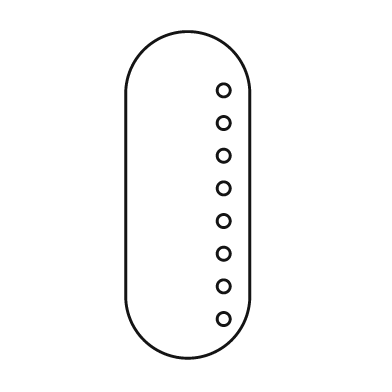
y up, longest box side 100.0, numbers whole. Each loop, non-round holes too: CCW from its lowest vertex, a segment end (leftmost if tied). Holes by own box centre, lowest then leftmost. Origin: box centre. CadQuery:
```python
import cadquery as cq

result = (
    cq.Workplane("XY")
    .moveTo(-19.0, -31.0)
    .threePointArc((0.0, -50.0), (19.0, -31.0))
    .lineTo(19.0, 31.0)
    .threePointArc((0.0, 50.0), (-19.0, 31.0))
    .close()
    .moveTo(11.0, -38.0)
    .circle(2.0)
    .moveTo(11.0, -28.0)
    .circle(2.0)
    .moveTo(11.0, -18.0)
    .circle(2.0)
    .moveTo(11.0, -8.0)
    .circle(2.0)
    .moveTo(11.0, 2.0)
    .circle(2.0)
    .moveTo(11.0, 12.0)
    .circle(2.0)
    .moveTo(11.0, 22.0)
    .circle(2.0)
    .moveTo(11.0, 32.0)
    .circle(2.0)
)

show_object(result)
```